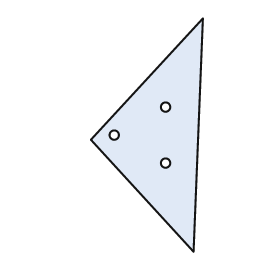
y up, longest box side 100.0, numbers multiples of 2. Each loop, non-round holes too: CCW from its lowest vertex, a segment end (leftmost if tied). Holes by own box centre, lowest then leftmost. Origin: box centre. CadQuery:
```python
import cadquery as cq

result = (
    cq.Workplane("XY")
    .moveTo(20.0, -50.0)
    .lineTo(24.0, 50.0)
    .lineTo(-24.0, -2.0)
    .close()
    .moveTo(8.0, -12.0)
    .circle(2.0)
    .moveTo(-14.0, 0.0)
    .circle(2.0)
    .moveTo(8.0, 12.0)
    .circle(2.0)
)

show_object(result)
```